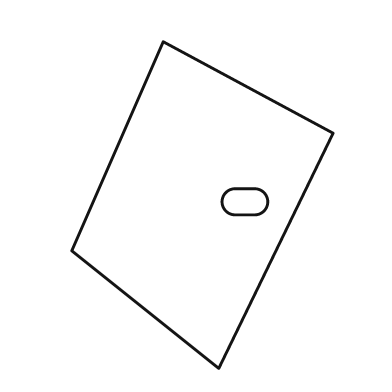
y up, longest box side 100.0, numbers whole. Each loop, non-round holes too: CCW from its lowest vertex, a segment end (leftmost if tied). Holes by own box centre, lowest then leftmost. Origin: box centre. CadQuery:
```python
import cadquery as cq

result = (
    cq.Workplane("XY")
    .moveTo(5.0, -50.0)
    .lineTo(40.0, 22.0)
    .lineTo(-12.0, 50.0)
    .lineTo(-40.0, -14.0)
    .close()
    .moveTo(10.0, -3.0)
    .lineTo(16.0, -3.0)
    .threePointArc((20.0, 1.0), (16.0, 5.0))
    .lineTo(10.0, 5.0)
    .threePointArc((6.0, 1.0), (10.0, -3.0))
    .close()
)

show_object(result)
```